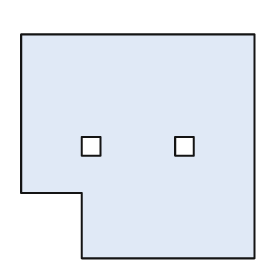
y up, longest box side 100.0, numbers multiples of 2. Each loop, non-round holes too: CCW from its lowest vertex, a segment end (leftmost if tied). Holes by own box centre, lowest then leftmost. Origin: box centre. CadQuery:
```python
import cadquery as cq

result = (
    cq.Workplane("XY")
    .moveTo(-24.0, -48.0)
    .lineTo(50.0, -48.0)
    .lineTo(50.0, 48.0)
    .lineTo(-50.0, 48.0)
    .lineTo(-50.0, -20.0)
    .lineTo(-24.0, -20.0)
    .close()
    .moveTo(-24.0, -4.0)
    .lineTo(-16.0, -4.0)
    .lineTo(-16.0, 4.0)
    .lineTo(-24.0, 4.0)
    .close()
    .moveTo(16.0, -4.0)
    .lineTo(24.0, -4.0)
    .lineTo(24.0, 4.0)
    .lineTo(16.0, 4.0)
    .close()
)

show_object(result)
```